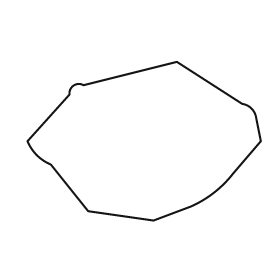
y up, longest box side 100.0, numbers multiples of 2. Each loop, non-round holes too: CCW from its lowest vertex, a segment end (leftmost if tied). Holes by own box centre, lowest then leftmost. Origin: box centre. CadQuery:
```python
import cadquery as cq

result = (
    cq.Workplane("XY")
    .moveTo(4.0, -34.0)
    .lineTo(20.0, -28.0)
    .threePointArc((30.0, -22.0), (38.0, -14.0))
    .lineTo(50.0, 0.0)
    .lineTo(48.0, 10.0)
    .threePointArc((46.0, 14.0), (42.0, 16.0))
    .lineTo(14.0, 34.0)
    .lineTo(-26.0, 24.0)
    .threePointArc((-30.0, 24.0), (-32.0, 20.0))
    .lineTo(-50.0, 0.0)
    .threePointArc((-46.0, -6.0), (-40.0, -10.0))
    .lineTo(-24.0, -30.0)
    .close()
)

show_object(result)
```